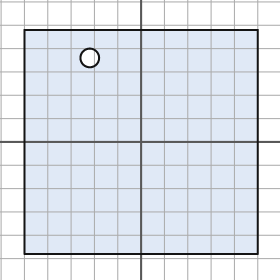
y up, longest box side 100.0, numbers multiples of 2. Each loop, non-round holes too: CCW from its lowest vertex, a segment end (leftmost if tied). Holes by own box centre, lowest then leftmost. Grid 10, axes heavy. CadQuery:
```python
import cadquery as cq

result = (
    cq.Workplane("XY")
    .moveTo(-50.0, -48.0)
    .lineTo(50.0, -48.0)
    .lineTo(50.0, 48.0)
    .lineTo(-50.0, 48.0)
    .close()
    .moveTo(-22.0, 36.0)
    .circle(4.0)
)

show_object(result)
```